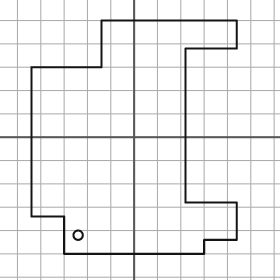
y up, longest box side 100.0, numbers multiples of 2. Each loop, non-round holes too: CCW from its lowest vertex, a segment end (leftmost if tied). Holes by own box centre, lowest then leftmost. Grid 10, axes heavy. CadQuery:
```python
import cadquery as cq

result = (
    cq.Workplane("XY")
    .moveTo(-30.0, -50.0)
    .lineTo(30.0, -50.0)
    .lineTo(30.0, -44.0)
    .lineTo(44.0, -44.0)
    .lineTo(44.0, -28.0)
    .lineTo(22.0, -28.0)
    .lineTo(22.0, 38.0)
    .lineTo(44.0, 38.0)
    .lineTo(44.0, 50.0)
    .lineTo(-14.0, 50.0)
    .lineTo(-14.0, 30.0)
    .lineTo(-44.0, 30.0)
    .lineTo(-44.0, -34.0)
    .lineTo(-30.0, -34.0)
    .close()
    .moveTo(-24.0, -42.0)
    .circle(2.0)
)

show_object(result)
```